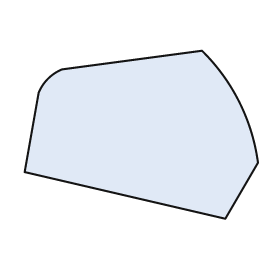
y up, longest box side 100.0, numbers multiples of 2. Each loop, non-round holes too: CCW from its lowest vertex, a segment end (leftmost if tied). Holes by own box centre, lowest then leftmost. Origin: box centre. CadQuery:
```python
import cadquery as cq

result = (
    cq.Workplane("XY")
    .moveTo(36.0, -36.0)
    .lineTo(50.0, -12.0)
    .threePointArc((42.0, 14.0), (26.0, 36.0))
    .lineTo(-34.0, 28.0)
    .threePointArc((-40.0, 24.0), (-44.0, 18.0))
    .lineTo(-50.0, -16.0)
    .close()
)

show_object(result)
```